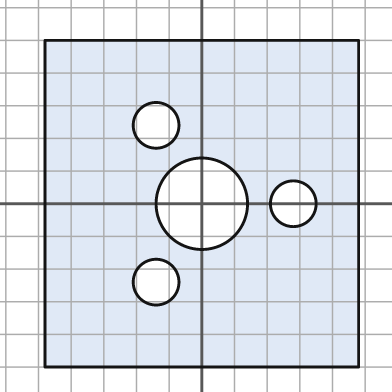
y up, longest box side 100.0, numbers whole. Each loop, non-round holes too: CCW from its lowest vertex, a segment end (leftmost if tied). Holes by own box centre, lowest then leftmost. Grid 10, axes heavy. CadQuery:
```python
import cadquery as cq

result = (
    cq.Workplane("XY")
    .moveTo(-48.0, -50.0)
    .lineTo(48.0, -50.0)
    .lineTo(48.0, 50.0)
    .lineTo(-48.0, 50.0)
    .close()
    .moveTo(-14.0, -24.0)
    .circle(7.0)
    .moveTo(0.0, 0.0)
    .circle(14.0)
    .moveTo(28.0, 0.0)
    .circle(7.0)
    .moveTo(-14.0, 24.0)
    .circle(7.0)
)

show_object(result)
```